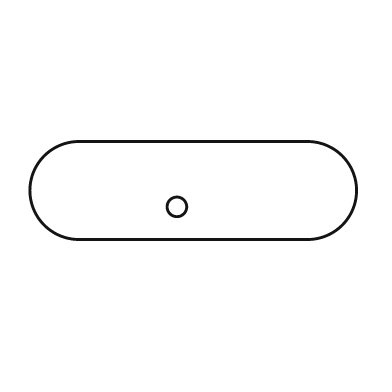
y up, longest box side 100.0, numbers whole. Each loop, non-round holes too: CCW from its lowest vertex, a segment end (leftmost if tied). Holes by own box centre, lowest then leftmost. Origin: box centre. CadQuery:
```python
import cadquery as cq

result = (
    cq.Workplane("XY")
    .moveTo(-35.0, -15.0)
    .lineTo(35.0, -15.0)
    .threePointArc((50.0, 0.0), (35.0, 15.0))
    .lineTo(-35.0, 15.0)
    .threePointArc((-50.0, 0.0), (-35.0, -15.0))
    .close()
    .moveTo(-5.0, -5.0)
    .circle(3.0)
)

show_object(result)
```